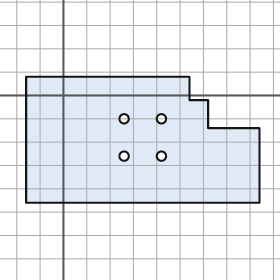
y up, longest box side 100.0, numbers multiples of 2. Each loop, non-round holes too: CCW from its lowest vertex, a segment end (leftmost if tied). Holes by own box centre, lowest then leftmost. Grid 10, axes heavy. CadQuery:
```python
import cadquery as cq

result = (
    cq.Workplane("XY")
    .moveTo(-16.0, -46.0)
    .lineTo(84.0, -46.0)
    .lineTo(84.0, -14.0)
    .lineTo(62.0, -14.0)
    .lineTo(62.0, -2.0)
    .lineTo(54.0, -2.0)
    .lineTo(54.0, 8.0)
    .lineTo(-16.0, 8.0)
    .close()
    .moveTo(26.0, -26.0)
    .circle(2.0)
    .moveTo(42.0, -26.0)
    .circle(2.0)
    .moveTo(26.0, -10.0)
    .circle(2.0)
    .moveTo(42.0, -10.0)
    .circle(2.0)
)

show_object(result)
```